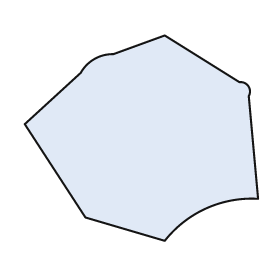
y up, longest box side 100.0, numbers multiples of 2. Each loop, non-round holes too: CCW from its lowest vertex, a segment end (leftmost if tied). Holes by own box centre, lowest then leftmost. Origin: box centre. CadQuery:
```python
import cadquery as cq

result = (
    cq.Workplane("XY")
    .moveTo(10.0, -44.0)
    .threePointArc((28.0, -30.0), (50.0, -26.0))
    .lineTo(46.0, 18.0)
    .threePointArc((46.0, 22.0), (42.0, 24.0))
    .lineTo(10.0, 44.0)
    .lineTo(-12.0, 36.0)
    .threePointArc((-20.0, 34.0), (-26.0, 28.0))
    .lineTo(-50.0, 6.0)
    .lineTo(-24.0, -34.0)
    .close()
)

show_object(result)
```